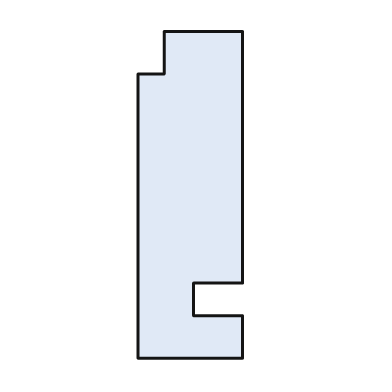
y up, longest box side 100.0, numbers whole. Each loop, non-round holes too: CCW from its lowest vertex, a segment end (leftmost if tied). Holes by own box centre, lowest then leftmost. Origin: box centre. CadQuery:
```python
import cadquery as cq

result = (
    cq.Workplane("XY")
    .moveTo(-16.0, -50.0)
    .lineTo(16.0, -50.0)
    .lineTo(16.0, -37.0)
    .lineTo(1.0, -37.0)
    .lineTo(1.0, -27.0)
    .lineTo(16.0, -27.0)
    .lineTo(16.0, 50.0)
    .lineTo(-8.0, 50.0)
    .lineTo(-8.0, 37.0)
    .lineTo(-16.0, 37.0)
    .close()
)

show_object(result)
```